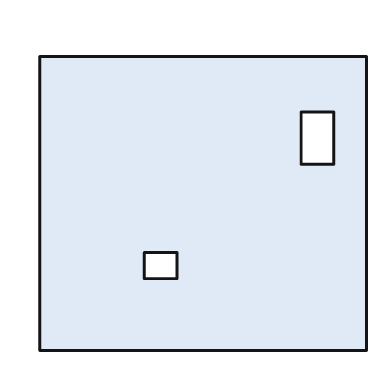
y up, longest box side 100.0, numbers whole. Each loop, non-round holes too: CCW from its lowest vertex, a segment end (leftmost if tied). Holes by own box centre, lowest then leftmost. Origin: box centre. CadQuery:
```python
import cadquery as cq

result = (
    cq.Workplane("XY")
    .moveTo(-50.0, -45.0)
    .lineTo(50.0, -45.0)
    .lineTo(50.0, 45.0)
    .lineTo(-50.0, 45.0)
    .close()
    .moveTo(-18.0, -23.0)
    .lineTo(-8.0, -23.0)
    .lineTo(-8.0, -15.0)
    .lineTo(-18.0, -15.0)
    .close()
    .moveTo(30.0, 12.0)
    .lineTo(40.0, 12.0)
    .lineTo(40.0, 28.0)
    .lineTo(30.0, 28.0)
    .close()
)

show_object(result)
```